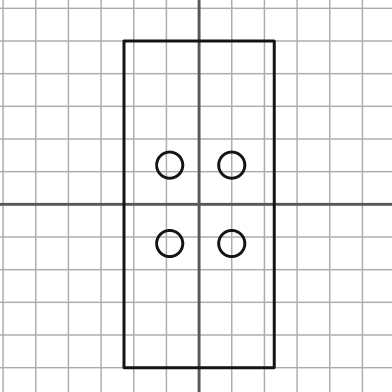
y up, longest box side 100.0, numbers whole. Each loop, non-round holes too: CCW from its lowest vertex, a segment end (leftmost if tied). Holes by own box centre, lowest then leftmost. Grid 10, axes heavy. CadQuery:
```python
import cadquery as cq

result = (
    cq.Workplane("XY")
    .moveTo(-23.0, -50.0)
    .lineTo(23.0, -50.0)
    .lineTo(23.0, 50.0)
    .lineTo(-23.0, 50.0)
    .close()
    .moveTo(-9.0, -12.0)
    .circle(4.0)
    .moveTo(10.0, -12.0)
    .circle(4.0)
    .moveTo(-9.0, 12.0)
    .circle(4.0)
    .moveTo(10.0, 12.0)
    .circle(4.0)
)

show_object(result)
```